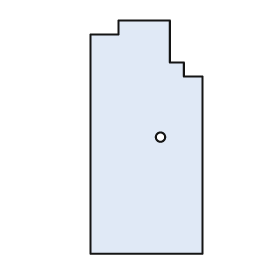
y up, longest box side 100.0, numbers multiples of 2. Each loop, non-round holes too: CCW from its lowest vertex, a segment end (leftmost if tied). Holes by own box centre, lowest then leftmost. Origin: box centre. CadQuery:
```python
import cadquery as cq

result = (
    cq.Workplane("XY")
    .moveTo(-24.0, -50.0)
    .lineTo(24.0, -50.0)
    .lineTo(24.0, 26.0)
    .lineTo(16.0, 26.0)
    .lineTo(16.0, 32.0)
    .lineTo(10.0, 32.0)
    .lineTo(10.0, 50.0)
    .lineTo(-12.0, 50.0)
    .lineTo(-12.0, 44.0)
    .lineTo(-24.0, 44.0)
    .close()
    .moveTo(6.0, 0.0)
    .circle(2.0)
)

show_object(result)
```